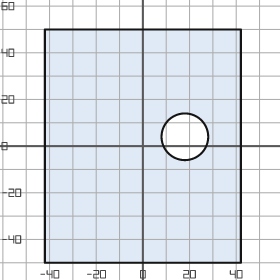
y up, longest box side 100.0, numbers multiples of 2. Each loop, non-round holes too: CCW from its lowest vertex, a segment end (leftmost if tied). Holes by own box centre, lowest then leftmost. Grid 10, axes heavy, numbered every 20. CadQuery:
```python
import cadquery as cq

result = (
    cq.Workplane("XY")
    .moveTo(-42.0, -50.0)
    .lineTo(42.0, -50.0)
    .lineTo(42.0, 50.0)
    .lineTo(-42.0, 50.0)
    .close()
    .moveTo(18.0, 4.0)
    .circle(10.0)
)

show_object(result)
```